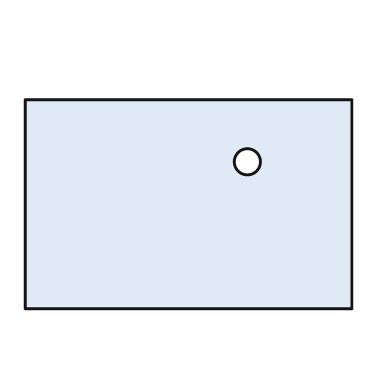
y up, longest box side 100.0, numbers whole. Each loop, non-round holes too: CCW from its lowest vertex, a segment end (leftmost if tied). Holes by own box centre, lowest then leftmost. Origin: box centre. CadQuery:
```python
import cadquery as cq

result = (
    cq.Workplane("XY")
    .moveTo(-50.0, -32.0)
    .lineTo(50.0, -32.0)
    .lineTo(50.0, 32.0)
    .lineTo(-50.0, 32.0)
    .close()
    .moveTo(18.0, 13.0)
    .circle(4.0)
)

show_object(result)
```